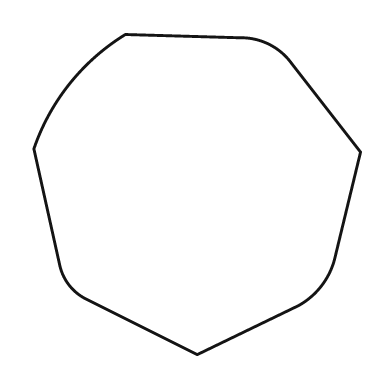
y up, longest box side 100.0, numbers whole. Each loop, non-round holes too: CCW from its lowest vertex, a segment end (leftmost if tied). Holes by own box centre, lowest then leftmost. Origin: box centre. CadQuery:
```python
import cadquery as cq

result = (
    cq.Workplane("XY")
    .moveTo(0.0, -49.0)
    .lineTo(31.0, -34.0)
    .threePointArc((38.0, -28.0), (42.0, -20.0))
    .lineTo(50.0, 13.0)
    .lineTo(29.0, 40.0)
    .threePointArc((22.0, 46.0), (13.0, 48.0))
    .lineTo(-22.0, 49.0)
    .threePointArc((-39.0, 34.0), (-50.0, 14.0))
    .lineTo(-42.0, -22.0)
    .threePointArc((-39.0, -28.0), (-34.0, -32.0))
    .close()
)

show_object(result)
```